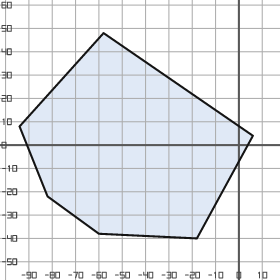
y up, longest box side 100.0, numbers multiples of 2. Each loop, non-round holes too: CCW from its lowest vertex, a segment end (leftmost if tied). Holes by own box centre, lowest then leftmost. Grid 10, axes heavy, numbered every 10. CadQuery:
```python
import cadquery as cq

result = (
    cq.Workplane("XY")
    .moveTo(-18.0, -40.0)
    .lineTo(6.0, 4.0)
    .lineTo(-58.0, 48.0)
    .lineTo(-94.0, 8.0)
    .lineTo(-82.0, -22.0)
    .lineTo(-60.0, -38.0)
    .close()
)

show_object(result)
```